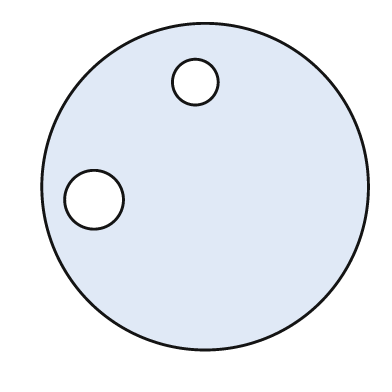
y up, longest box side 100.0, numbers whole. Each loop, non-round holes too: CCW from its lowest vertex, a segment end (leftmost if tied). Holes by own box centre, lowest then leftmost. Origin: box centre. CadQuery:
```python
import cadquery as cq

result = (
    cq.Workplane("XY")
    .moveTo(0.0, 0.0)
    .circle(50.0)
    .moveTo(-34.0, -4.0)
    .circle(9.0)
    .moveTo(-3.0, 32.0)
    .circle(7.0)
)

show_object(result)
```